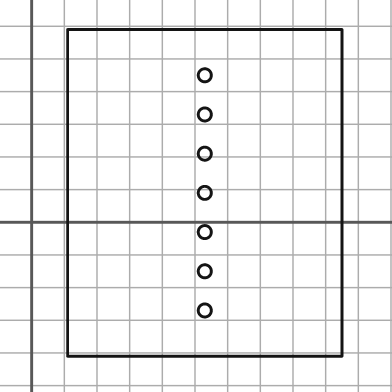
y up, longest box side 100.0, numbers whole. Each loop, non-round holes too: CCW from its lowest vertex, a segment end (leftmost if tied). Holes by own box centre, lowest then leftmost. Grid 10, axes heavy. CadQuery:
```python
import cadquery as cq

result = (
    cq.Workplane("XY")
    .moveTo(11.0, -41.0)
    .lineTo(95.0, -41.0)
    .lineTo(95.0, 59.0)
    .lineTo(11.0, 59.0)
    .close()
    .moveTo(53.0, -27.0)
    .circle(2.0)
    .moveTo(53.0, -15.0)
    .circle(2.0)
    .moveTo(53.0, -3.0)
    .circle(2.0)
    .moveTo(53.0, 9.0)
    .circle(2.0)
    .moveTo(53.0, 21.0)
    .circle(2.0)
    .moveTo(53.0, 33.0)
    .circle(2.0)
    .moveTo(53.0, 45.0)
    .circle(2.0)
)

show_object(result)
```